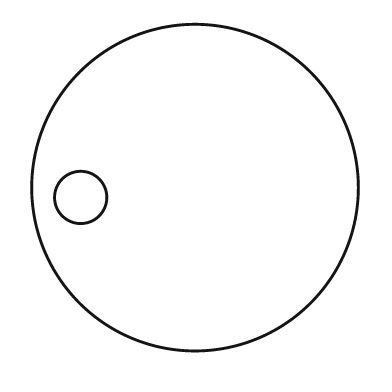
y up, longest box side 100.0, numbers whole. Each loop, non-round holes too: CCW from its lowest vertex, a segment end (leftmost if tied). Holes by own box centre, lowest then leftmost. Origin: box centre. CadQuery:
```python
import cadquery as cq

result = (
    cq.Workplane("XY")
    .moveTo(0.0, 0.0)
    .circle(50.0)
    .moveTo(-35.0, -3.0)
    .circle(8.0)
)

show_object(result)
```